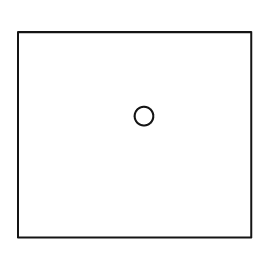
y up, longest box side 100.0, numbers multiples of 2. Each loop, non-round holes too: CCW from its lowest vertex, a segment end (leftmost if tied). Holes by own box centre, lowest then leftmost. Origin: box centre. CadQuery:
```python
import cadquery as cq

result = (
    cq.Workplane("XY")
    .moveTo(-50.0, -44.0)
    .lineTo(50.0, -44.0)
    .lineTo(50.0, 44.0)
    .lineTo(-50.0, 44.0)
    .close()
    .moveTo(4.0, 8.0)
    .circle(4.0)
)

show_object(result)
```